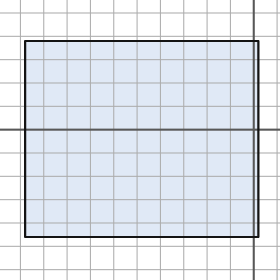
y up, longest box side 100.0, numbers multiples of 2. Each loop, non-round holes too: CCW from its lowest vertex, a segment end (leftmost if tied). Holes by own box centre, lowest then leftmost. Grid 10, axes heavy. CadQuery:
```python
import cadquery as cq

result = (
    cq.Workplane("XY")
    .moveTo(-98.0, -46.0)
    .lineTo(2.0, -46.0)
    .lineTo(2.0, 38.0)
    .lineTo(-98.0, 38.0)
    .close()
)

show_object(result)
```